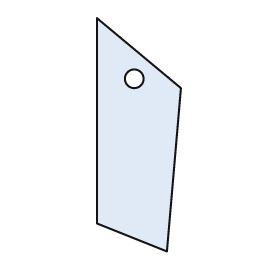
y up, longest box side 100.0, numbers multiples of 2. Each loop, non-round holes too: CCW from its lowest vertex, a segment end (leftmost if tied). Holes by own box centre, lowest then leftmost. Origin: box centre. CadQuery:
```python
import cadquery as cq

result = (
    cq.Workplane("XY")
    .moveTo(12.0, -50.0)
    .lineTo(18.0, 20.0)
    .lineTo(-18.0, 50.0)
    .lineTo(-18.0, -38.0)
    .close()
    .moveTo(-2.0, 24.0)
    .circle(4.0)
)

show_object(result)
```